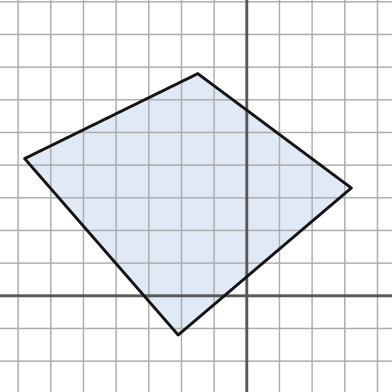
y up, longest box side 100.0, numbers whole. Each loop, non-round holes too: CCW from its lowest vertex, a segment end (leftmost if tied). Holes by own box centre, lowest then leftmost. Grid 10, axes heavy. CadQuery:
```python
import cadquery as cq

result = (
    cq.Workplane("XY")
    .moveTo(-21.0, -12.0)
    .lineTo(32.0, 33.0)
    .lineTo(-15.0, 68.0)
    .lineTo(-68.0, 42.0)
    .close()
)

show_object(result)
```